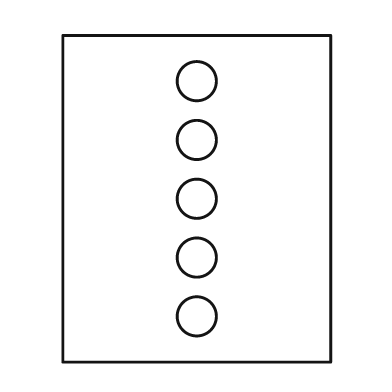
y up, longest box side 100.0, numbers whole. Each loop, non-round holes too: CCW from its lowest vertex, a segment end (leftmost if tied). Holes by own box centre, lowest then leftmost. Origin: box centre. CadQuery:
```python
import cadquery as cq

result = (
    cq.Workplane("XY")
    .moveTo(-41.0, -50.0)
    .lineTo(41.0, -50.0)
    .lineTo(41.0, 50.0)
    .lineTo(-41.0, 50.0)
    .close()
    .moveTo(0.0, -36.0)
    .circle(6.0)
    .moveTo(0.0, -18.0)
    .circle(6.0)
    .moveTo(0.0, 0.0)
    .circle(6.0)
    .moveTo(0.0, 18.0)
    .circle(6.0)
    .moveTo(0.0, 36.0)
    .circle(6.0)
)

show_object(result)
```